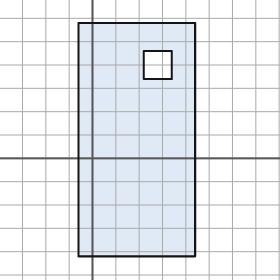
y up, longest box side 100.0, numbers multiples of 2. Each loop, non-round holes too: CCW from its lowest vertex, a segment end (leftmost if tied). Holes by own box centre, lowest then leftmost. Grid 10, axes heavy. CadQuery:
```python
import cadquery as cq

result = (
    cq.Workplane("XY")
    .moveTo(-6.0, -42.0)
    .lineTo(44.0, -42.0)
    .lineTo(44.0, 58.0)
    .lineTo(-6.0, 58.0)
    .close()
    .moveTo(22.0, 34.0)
    .lineTo(34.0, 34.0)
    .lineTo(34.0, 46.0)
    .lineTo(22.0, 46.0)
    .close()
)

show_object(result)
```